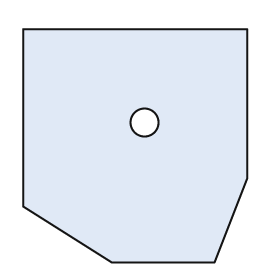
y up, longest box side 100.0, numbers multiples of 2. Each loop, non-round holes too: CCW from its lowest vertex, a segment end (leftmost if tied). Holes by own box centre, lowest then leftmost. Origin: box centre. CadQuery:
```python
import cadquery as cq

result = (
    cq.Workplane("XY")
    .moveTo(-10.0, -50.0)
    .lineTo(34.0, -50.0)
    .lineTo(48.0, -14.0)
    .lineTo(48.0, 50.0)
    .lineTo(-48.0, 50.0)
    .lineTo(-48.0, -26.0)
    .close()
    .moveTo(4.0, 10.0)
    .circle(6.0)
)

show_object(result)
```